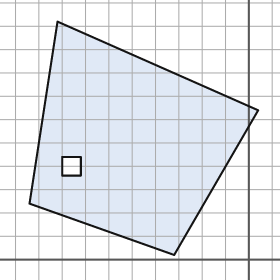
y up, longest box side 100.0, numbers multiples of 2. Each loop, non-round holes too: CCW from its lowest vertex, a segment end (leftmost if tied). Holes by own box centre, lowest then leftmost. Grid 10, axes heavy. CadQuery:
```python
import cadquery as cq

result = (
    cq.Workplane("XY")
    .moveTo(-32.0, 2.0)
    .lineTo(4.0, 64.0)
    .lineTo(-82.0, 102.0)
    .lineTo(-94.0, 24.0)
    .close()
    .moveTo(-80.0, 36.0)
    .lineTo(-72.0, 36.0)
    .lineTo(-72.0, 44.0)
    .lineTo(-80.0, 44.0)
    .close()
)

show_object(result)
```